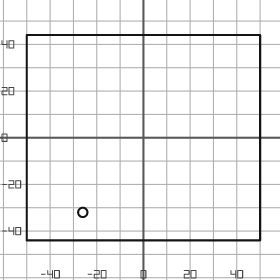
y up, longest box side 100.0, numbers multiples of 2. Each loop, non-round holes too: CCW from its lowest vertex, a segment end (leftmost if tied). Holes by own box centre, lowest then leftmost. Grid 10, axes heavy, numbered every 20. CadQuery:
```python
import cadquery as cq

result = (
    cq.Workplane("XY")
    .moveTo(-50.0, -44.0)
    .lineTo(50.0, -44.0)
    .lineTo(50.0, 44.0)
    .lineTo(-50.0, 44.0)
    .close()
    .moveTo(-26.0, -32.0)
    .circle(2.0)
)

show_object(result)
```